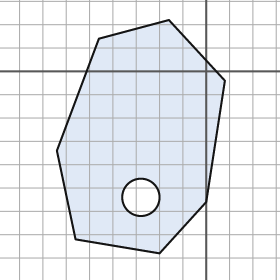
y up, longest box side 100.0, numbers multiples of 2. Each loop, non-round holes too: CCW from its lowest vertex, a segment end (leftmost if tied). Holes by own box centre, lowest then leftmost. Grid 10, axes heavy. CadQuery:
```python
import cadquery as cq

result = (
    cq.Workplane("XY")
    .moveTo(-20.0, -78.0)
    .lineTo(0.0, -56.0)
    .lineTo(8.0, -4.0)
    .lineTo(-16.0, 22.0)
    .lineTo(-46.0, 14.0)
    .lineTo(-64.0, -34.0)
    .lineTo(-56.0, -72.0)
    .close()
    .moveTo(-28.0, -54.0)
    .circle(8.0)
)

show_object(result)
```